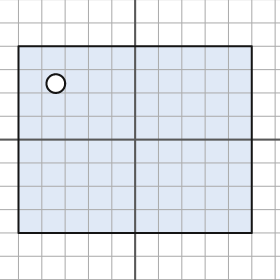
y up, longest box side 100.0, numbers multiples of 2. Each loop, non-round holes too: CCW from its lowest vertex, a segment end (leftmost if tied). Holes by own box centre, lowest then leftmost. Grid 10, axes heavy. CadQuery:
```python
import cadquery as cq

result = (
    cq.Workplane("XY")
    .moveTo(-50.0, -40.0)
    .lineTo(50.0, -40.0)
    .lineTo(50.0, 40.0)
    .lineTo(-50.0, 40.0)
    .close()
    .moveTo(-34.0, 24.0)
    .circle(4.0)
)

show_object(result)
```